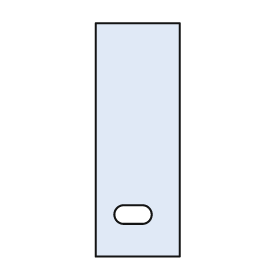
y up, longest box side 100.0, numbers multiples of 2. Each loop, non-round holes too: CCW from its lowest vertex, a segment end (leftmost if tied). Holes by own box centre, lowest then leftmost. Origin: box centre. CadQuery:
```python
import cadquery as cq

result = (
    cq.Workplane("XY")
    .moveTo(-18.0, -50.0)
    .lineTo(18.0, -50.0)
    .lineTo(18.0, 50.0)
    .lineTo(-18.0, 50.0)
    .close()
    .moveTo(-6.0, -36.0)
    .lineTo(2.0, -36.0)
    .threePointArc((6.0, -32.0), (2.0, -28.0))
    .lineTo(-6.0, -28.0)
    .threePointArc((-10.0, -32.0), (-6.0, -36.0))
    .close()
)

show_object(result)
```